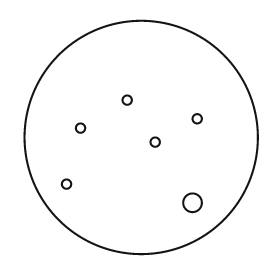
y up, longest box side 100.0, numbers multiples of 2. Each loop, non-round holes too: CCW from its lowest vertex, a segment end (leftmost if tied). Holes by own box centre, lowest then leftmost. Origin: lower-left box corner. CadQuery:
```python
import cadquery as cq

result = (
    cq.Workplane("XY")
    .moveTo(50.0, 50.0)
    .circle(50.0)
    .moveTo(72.0, 22.0)
    .circle(4.0)
    .moveTo(18.0, 30.0)
    .circle(2.0)
    .moveTo(56.0, 48.0)
    .circle(2.0)
    .moveTo(24.0, 54.0)
    .circle(2.0)
    .moveTo(74.0, 58.0)
    .circle(2.0)
    .moveTo(44.0, 66.0)
    .circle(2.0)
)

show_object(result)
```